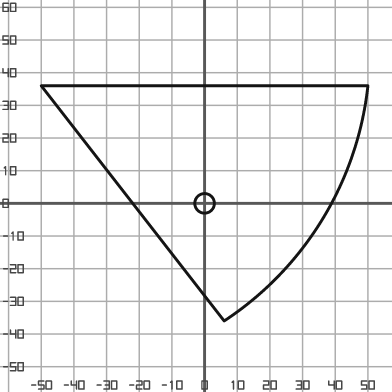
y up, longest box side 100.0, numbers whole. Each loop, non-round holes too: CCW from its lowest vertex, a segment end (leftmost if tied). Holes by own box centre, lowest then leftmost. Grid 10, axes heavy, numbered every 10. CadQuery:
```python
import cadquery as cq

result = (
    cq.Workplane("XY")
    .moveTo(6.0, -36.0)
    .threePointArc((36.0, -5.0), (50.0, 36.0))
    .lineTo(-50.0, 36.0)
    .close()
    .moveTo(0.0, 0.0)
    .circle(3.0)
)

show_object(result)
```